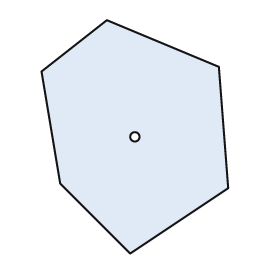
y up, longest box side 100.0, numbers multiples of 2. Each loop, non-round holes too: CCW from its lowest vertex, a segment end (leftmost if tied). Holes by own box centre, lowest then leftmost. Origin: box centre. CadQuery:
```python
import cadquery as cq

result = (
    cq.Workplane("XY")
    .moveTo(-2.0, -50.0)
    .lineTo(40.0, -22.0)
    .lineTo(36.0, 30.0)
    .lineTo(-12.0, 50.0)
    .lineTo(-40.0, 28.0)
    .lineTo(-32.0, -20.0)
    .close()
    .moveTo(0.0, 0.0)
    .circle(2.0)
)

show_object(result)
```